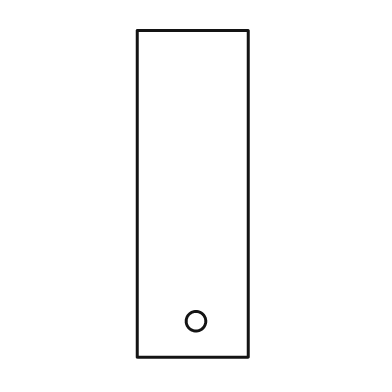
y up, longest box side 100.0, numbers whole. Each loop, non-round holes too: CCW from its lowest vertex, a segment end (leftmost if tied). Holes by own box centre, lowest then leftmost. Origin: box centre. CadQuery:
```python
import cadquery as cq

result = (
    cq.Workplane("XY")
    .moveTo(-17.0, -50.0)
    .lineTo(17.0, -50.0)
    .lineTo(17.0, 50.0)
    .lineTo(-17.0, 50.0)
    .close()
    .moveTo(1.0, -39.0)
    .circle(3.0)
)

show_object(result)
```